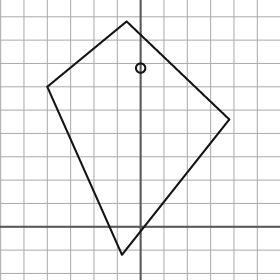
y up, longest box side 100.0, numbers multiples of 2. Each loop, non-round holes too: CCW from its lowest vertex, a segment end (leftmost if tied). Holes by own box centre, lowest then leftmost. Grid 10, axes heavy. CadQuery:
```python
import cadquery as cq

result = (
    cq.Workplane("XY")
    .moveTo(-8.0, -12.0)
    .lineTo(38.0, 46.0)
    .lineTo(-6.0, 88.0)
    .lineTo(-40.0, 60.0)
    .close()
    .moveTo(0.0, 68.0)
    .circle(2.0)
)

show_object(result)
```